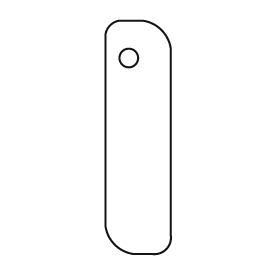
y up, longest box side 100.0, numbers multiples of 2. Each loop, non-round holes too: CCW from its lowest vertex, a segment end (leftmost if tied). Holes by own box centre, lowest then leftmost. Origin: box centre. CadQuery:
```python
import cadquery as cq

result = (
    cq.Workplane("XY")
    .moveTo(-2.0, -50.0)
    .lineTo(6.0, -50.0)
    .threePointArc((12.0, -48.0), (14.0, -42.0))
    .lineTo(14.0, 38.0)
    .threePointArc((10.0, 46.0), (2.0, 50.0))
    .lineTo(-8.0, 50.0)
    .threePointArc((-12.0, 48.0), (-14.0, 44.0))
    .lineTo(-14.0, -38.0)
    .threePointArc((-10.0, -46.0), (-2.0, -50.0))
    .close()
    .moveTo(-4.0, 34.0)
    .circle(4.0)
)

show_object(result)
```